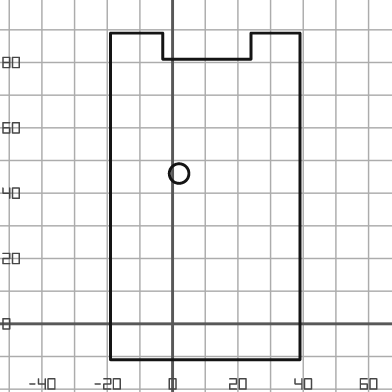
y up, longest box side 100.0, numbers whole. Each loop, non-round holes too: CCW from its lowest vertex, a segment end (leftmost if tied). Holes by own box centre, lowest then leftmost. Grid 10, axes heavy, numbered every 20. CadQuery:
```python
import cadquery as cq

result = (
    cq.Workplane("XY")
    .moveTo(-19.0, -11.0)
    .lineTo(39.0, -11.0)
    .lineTo(39.0, 89.0)
    .lineTo(24.0, 89.0)
    .lineTo(24.0, 81.0)
    .lineTo(-3.0, 81.0)
    .lineTo(-3.0, 89.0)
    .lineTo(-19.0, 89.0)
    .close()
    .moveTo(2.0, 46.0)
    .circle(3.0)
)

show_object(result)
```